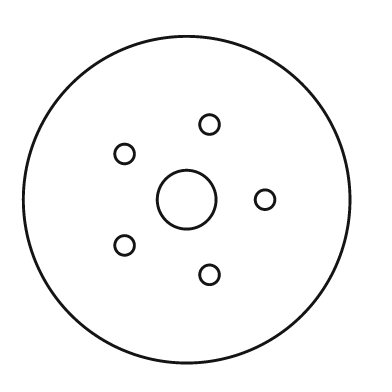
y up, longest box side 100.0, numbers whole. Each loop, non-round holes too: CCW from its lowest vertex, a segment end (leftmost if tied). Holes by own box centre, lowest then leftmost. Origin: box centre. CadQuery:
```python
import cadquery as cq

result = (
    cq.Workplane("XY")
    .moveTo(0.0, 0.0)
    .circle(50.0)
    .moveTo(7.0, -23.0)
    .circle(3.0)
    .moveTo(-19.0, -14.0)
    .circle(3.0)
    .moveTo(0.0, 0.0)
    .circle(9.0)
    .moveTo(24.0, 0.0)
    .circle(3.0)
    .moveTo(-19.0, 14.0)
    .circle(3.0)
    .moveTo(7.0, 23.0)
    .circle(3.0)
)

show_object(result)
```